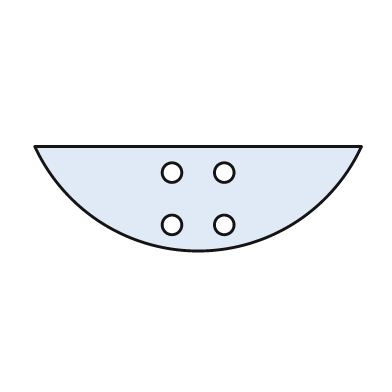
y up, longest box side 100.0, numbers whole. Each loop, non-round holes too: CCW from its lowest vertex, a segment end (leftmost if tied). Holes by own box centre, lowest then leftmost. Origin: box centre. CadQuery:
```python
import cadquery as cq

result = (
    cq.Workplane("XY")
    .moveTo(-50.0, 16.0)
    .threePointArc((0.0, -16.0), (50.0, 16.0))
    .close()
    .moveTo(-8.0, -8.0)
    .circle(3.0)
    .moveTo(8.0, -8.0)
    .circle(3.0)
    .moveTo(-8.0, 8.0)
    .circle(3.0)
    .moveTo(8.0, 8.0)
    .circle(3.0)
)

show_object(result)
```